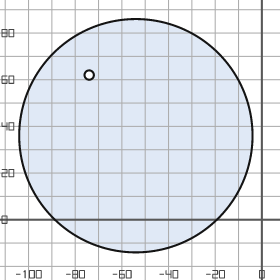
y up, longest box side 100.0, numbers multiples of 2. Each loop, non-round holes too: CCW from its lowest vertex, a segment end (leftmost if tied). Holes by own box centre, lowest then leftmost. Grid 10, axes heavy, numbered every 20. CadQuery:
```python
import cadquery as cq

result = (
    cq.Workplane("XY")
    .moveTo(-54.0, 36.0)
    .circle(50.0)
    .moveTo(-74.0, 62.0)
    .circle(2.0)
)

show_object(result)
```